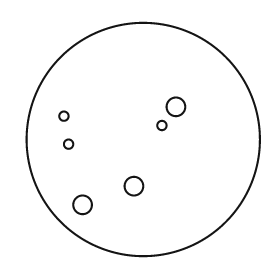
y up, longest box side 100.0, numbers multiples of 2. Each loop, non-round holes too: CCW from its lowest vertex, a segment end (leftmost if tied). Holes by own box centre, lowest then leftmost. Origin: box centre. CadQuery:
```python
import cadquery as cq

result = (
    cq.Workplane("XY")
    .moveTo(0.0, 0.0)
    .circle(50.0)
    .moveTo(-26.0, -28.0)
    .circle(4.0)
    .moveTo(-4.0, -20.0)
    .circle(4.0)
    .moveTo(-32.0, -2.0)
    .circle(2.0)
    .moveTo(8.0, 6.0)
    .circle(2.0)
    .moveTo(-34.0, 10.0)
    .circle(2.0)
    .moveTo(14.0, 14.0)
    .circle(4.0)
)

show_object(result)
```